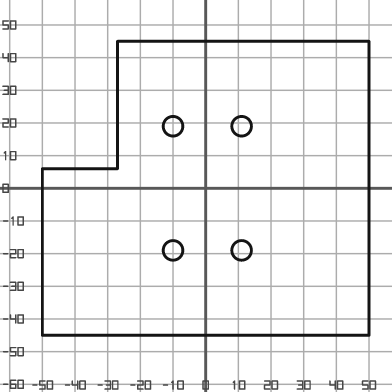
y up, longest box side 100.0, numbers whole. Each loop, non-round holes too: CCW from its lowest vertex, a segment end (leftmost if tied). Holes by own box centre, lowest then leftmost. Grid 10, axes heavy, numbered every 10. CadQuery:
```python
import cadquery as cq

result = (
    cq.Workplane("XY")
    .moveTo(-50.0, -45.0)
    .lineTo(50.0, -45.0)
    .lineTo(50.0, 45.0)
    .lineTo(-27.0, 45.0)
    .lineTo(-27.0, 6.0)
    .lineTo(-50.0, 6.0)
    .close()
    .moveTo(-10.0, -19.0)
    .circle(3.0)
    .moveTo(11.0, -19.0)
    .circle(3.0)
    .moveTo(-10.0, 19.0)
    .circle(3.0)
    .moveTo(11.0, 19.0)
    .circle(3.0)
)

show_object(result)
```